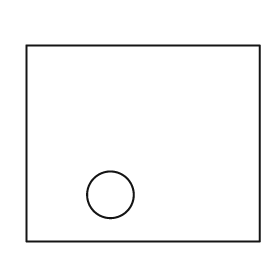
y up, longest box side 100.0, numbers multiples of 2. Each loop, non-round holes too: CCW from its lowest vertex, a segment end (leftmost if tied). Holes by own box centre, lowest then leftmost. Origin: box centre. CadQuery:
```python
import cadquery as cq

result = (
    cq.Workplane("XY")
    .moveTo(-50.0, -42.0)
    .lineTo(50.0, -42.0)
    .lineTo(50.0, 42.0)
    .lineTo(-50.0, 42.0)
    .close()
    .moveTo(-14.0, -22.0)
    .circle(10.0)
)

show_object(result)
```